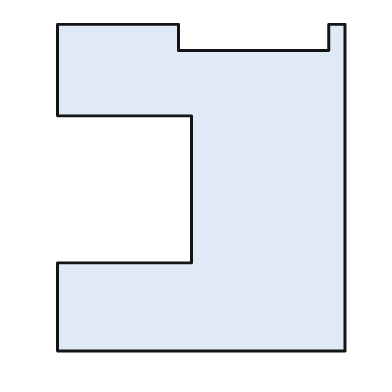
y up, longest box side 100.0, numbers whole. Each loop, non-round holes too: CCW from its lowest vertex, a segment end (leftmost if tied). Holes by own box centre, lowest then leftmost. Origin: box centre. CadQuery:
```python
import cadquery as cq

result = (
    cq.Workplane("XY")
    .moveTo(-44.0, -50.0)
    .lineTo(44.0, -50.0)
    .lineTo(44.0, 50.0)
    .lineTo(39.0, 50.0)
    .lineTo(39.0, 42.0)
    .lineTo(-7.0, 42.0)
    .lineTo(-7.0, 50.0)
    .lineTo(-44.0, 50.0)
    .lineTo(-44.0, 22.0)
    .lineTo(-3.0, 22.0)
    .lineTo(-3.0, -23.0)
    .lineTo(-44.0, -23.0)
    .close()
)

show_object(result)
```